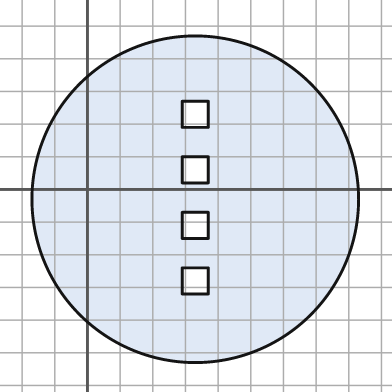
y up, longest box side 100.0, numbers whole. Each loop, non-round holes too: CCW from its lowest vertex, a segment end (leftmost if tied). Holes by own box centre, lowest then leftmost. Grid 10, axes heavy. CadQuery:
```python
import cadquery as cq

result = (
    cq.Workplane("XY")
    .moveTo(33.0, -3.0)
    .circle(50.0)
    .moveTo(29.0, -32.0)
    .lineTo(37.0, -32.0)
    .lineTo(37.0, -24.0)
    .lineTo(29.0, -24.0)
    .close()
    .moveTo(29.0, -15.0)
    .lineTo(37.0, -15.0)
    .lineTo(37.0, -7.0)
    .lineTo(29.0, -7.0)
    .close()
    .moveTo(29.0, 2.0)
    .lineTo(37.0, 2.0)
    .lineTo(37.0, 10.0)
    .lineTo(29.0, 10.0)
    .close()
    .moveTo(29.0, 19.0)
    .lineTo(37.0, 19.0)
    .lineTo(37.0, 27.0)
    .lineTo(29.0, 27.0)
    .close()
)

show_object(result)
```